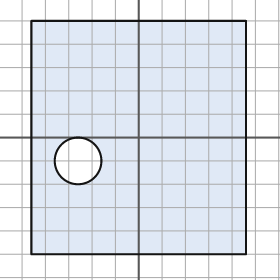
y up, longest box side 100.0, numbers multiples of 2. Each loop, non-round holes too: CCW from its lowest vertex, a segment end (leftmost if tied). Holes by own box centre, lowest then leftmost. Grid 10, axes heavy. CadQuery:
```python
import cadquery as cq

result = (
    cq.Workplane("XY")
    .moveTo(-46.0, -50.0)
    .lineTo(46.0, -50.0)
    .lineTo(46.0, 50.0)
    .lineTo(-46.0, 50.0)
    .close()
    .moveTo(-26.0, -10.0)
    .circle(10.0)
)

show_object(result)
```